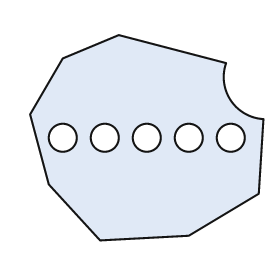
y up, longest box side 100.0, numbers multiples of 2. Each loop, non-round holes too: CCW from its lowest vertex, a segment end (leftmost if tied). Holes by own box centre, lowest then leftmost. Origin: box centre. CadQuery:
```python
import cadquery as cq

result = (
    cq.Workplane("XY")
    .moveTo(-20.0, -44.0)
    .lineTo(18.0, -42.0)
    .lineTo(48.0, -24.0)
    .lineTo(50.0, 8.0)
    .threePointArc((36.0, 16.0), (34.0, 32.0))
    .lineTo(-12.0, 44.0)
    .lineTo(-36.0, 34.0)
    .lineTo(-50.0, 10.0)
    .lineTo(-42.0, -20.0)
    .close()
    .moveTo(-36.0, 0.0)
    .circle(6.0)
    .moveTo(-18.0, 0.0)
    .circle(6.0)
    .moveTo(0.0, 0.0)
    .circle(6.0)
    .moveTo(18.0, 0.0)
    .circle(6.0)
    .moveTo(36.0, 0.0)
    .circle(6.0)
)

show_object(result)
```